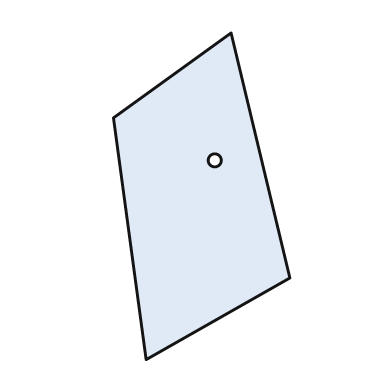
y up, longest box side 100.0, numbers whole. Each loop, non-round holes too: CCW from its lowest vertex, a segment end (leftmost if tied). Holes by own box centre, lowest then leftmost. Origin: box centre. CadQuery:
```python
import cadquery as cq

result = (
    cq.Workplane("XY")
    .moveTo(-17.0, -50.0)
    .lineTo(27.0, -25.0)
    .lineTo(9.0, 50.0)
    .lineTo(-27.0, 24.0)
    .close()
    .moveTo(4.0, 11.0)
    .circle(2.0)
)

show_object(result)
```